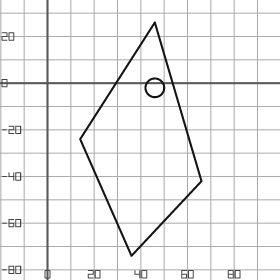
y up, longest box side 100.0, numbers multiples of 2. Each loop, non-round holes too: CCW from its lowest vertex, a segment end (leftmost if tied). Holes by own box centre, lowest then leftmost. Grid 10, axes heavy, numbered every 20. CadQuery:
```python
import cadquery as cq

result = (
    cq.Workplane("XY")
    .moveTo(36.0, -74.0)
    .lineTo(66.0, -42.0)
    .lineTo(46.0, 26.0)
    .lineTo(14.0, -24.0)
    .close()
    .moveTo(46.0, -2.0)
    .circle(4.0)
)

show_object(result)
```